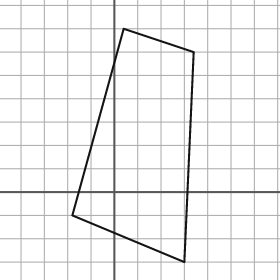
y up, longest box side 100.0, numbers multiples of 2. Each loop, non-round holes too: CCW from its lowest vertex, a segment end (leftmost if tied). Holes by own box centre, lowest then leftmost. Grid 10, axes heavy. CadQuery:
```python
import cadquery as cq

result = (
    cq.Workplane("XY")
    .moveTo(30.0, -30.0)
    .lineTo(34.0, 60.0)
    .lineTo(4.0, 70.0)
    .lineTo(-18.0, -10.0)
    .close()
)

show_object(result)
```